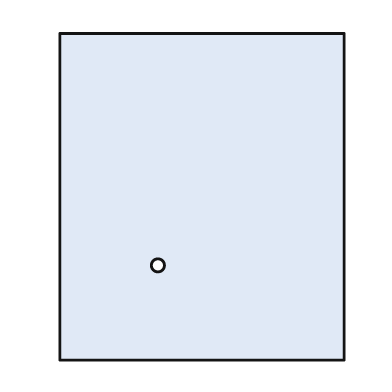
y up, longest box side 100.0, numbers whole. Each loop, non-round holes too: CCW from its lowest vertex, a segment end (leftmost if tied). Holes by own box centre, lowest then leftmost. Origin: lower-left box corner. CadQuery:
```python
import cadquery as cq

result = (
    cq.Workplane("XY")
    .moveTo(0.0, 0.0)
    .lineTo(87.0, 0.0)
    .lineTo(87.0, 100.0)
    .lineTo(0.0, 100.0)
    .close()
    .moveTo(30.0, 29.0)
    .circle(2.0)
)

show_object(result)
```